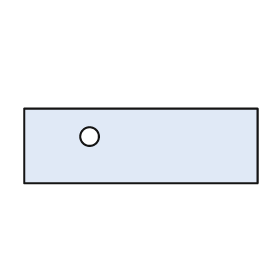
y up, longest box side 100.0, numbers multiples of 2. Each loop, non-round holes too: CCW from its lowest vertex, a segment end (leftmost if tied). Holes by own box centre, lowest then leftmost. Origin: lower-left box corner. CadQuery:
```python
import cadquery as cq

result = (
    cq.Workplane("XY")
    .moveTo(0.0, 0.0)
    .lineTo(100.0, 0.0)
    .lineTo(100.0, 32.0)
    .lineTo(0.0, 32.0)
    .close()
    .moveTo(28.0, 20.0)
    .circle(4.0)
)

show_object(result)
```